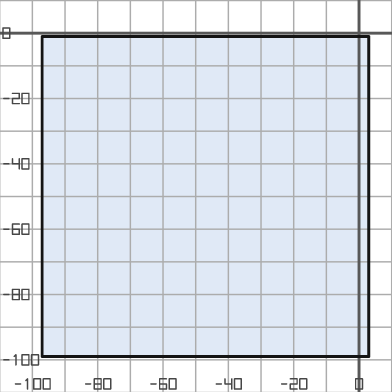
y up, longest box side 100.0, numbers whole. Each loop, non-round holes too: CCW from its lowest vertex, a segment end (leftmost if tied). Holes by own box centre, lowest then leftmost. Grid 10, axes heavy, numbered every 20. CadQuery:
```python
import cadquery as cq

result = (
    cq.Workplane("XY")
    .moveTo(-97.0, -99.0)
    .lineTo(3.0, -99.0)
    .lineTo(3.0, -1.0)
    .lineTo(-97.0, -1.0)
    .close()
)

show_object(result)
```